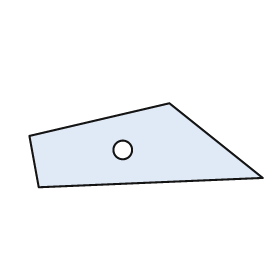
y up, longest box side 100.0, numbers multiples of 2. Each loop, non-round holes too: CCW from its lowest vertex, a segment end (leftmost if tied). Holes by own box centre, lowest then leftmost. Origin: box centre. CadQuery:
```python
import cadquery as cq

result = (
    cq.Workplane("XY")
    .moveTo(-46.0, -18.0)
    .lineTo(50.0, -14.0)
    .lineTo(10.0, 18.0)
    .lineTo(-50.0, 4.0)
    .close()
    .moveTo(-10.0, -2.0)
    .circle(4.0)
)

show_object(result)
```